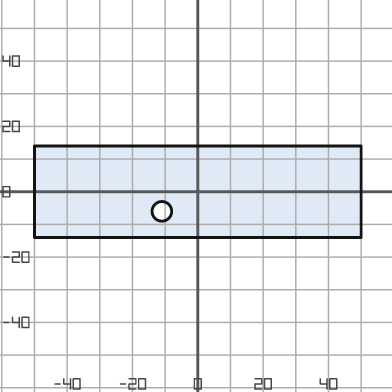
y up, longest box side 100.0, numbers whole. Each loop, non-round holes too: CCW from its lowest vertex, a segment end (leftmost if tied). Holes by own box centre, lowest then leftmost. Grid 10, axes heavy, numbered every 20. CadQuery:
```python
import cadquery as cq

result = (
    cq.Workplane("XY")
    .moveTo(-50.0, -14.0)
    .lineTo(50.0, -14.0)
    .lineTo(50.0, 14.0)
    .lineTo(-50.0, 14.0)
    .close()
    .moveTo(-11.0, -6.0)
    .circle(3.0)
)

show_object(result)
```